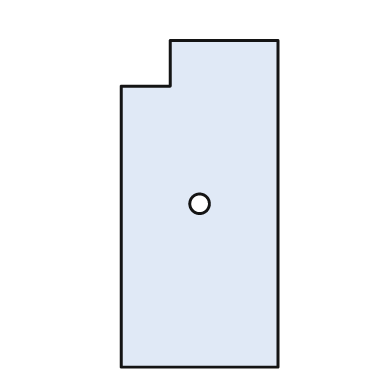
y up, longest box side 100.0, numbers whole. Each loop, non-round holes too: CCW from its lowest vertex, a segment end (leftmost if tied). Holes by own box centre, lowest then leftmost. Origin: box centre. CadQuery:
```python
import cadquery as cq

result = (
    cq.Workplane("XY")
    .moveTo(-24.0, -50.0)
    .lineTo(24.0, -50.0)
    .lineTo(24.0, 50.0)
    .lineTo(-9.0, 50.0)
    .lineTo(-9.0, 36.0)
    .lineTo(-24.0, 36.0)
    .close()
    .moveTo(0.0, 0.0)
    .circle(3.0)
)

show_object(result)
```